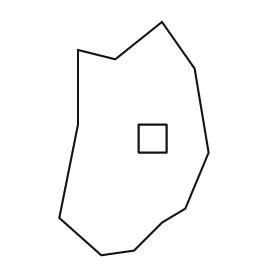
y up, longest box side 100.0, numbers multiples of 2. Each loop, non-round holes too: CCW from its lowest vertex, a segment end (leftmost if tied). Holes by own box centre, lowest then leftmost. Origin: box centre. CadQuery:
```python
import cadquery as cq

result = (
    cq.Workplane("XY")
    .moveTo(-14.0, -50.0)
    .lineTo(0.0, -48.0)
    .lineTo(12.0, -36.0)
    .lineTo(22.0, -30.0)
    .lineTo(32.0, -6.0)
    .lineTo(26.0, 30.0)
    .lineTo(12.0, 50.0)
    .lineTo(-8.0, 34.0)
    .lineTo(-24.0, 38.0)
    .lineTo(-24.0, 6.0)
    .lineTo(-32.0, -34.0)
    .close()
    .moveTo(2.0, -6.0)
    .lineTo(14.0, -6.0)
    .lineTo(14.0, 6.0)
    .lineTo(2.0, 6.0)
    .close()
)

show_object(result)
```